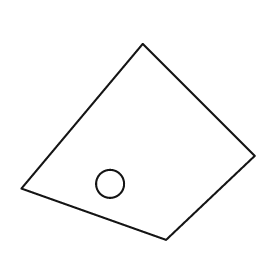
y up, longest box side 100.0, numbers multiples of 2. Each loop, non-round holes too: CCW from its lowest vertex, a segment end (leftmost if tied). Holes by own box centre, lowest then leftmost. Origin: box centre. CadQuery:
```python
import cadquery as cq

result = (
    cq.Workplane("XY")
    .moveTo(12.0, -42.0)
    .lineTo(50.0, -6.0)
    .lineTo(2.0, 42.0)
    .lineTo(-50.0, -20.0)
    .close()
    .moveTo(-12.0, -18.0)
    .circle(6.0)
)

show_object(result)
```